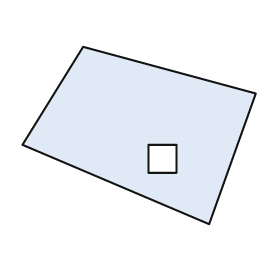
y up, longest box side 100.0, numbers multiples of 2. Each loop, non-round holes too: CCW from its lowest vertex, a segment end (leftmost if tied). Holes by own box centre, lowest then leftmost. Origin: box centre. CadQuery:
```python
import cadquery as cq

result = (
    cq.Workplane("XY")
    .moveTo(30.0, -38.0)
    .lineTo(50.0, 18.0)
    .lineTo(-24.0, 38.0)
    .lineTo(-50.0, -4.0)
    .close()
    .moveTo(4.0, -16.0)
    .lineTo(16.0, -16.0)
    .lineTo(16.0, -4.0)
    .lineTo(4.0, -4.0)
    .close()
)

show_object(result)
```